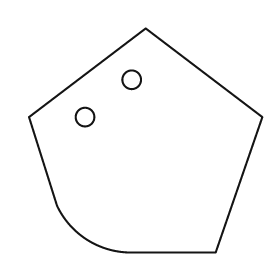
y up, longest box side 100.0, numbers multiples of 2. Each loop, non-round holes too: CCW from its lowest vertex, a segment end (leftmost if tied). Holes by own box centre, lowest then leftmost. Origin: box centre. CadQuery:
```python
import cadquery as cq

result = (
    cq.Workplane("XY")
    .moveTo(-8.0, -48.0)
    .lineTo(30.0, -48.0)
    .lineTo(50.0, 10.0)
    .lineTo(0.0, 48.0)
    .lineTo(-50.0, 10.0)
    .lineTo(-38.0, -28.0)
    .threePointArc((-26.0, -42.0), (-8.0, -48.0))
    .close()
    .moveTo(-26.0, 10.0)
    .circle(4.0)
    .moveTo(-6.0, 26.0)
    .circle(4.0)
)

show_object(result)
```